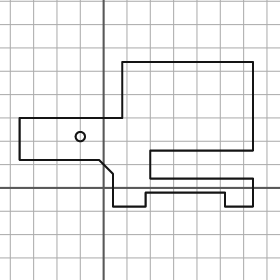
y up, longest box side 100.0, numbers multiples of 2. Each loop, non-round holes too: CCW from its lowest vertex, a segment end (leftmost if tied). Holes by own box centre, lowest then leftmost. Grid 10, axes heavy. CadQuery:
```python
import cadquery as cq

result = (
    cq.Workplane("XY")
    .moveTo(4.0, -8.0)
    .lineTo(18.0, -8.0)
    .lineTo(18.0, -2.0)
    .lineTo(52.0, -2.0)
    .lineTo(52.0, -8.0)
    .lineTo(64.0, -8.0)
    .lineTo(64.0, 4.0)
    .lineTo(20.0, 4.0)
    .lineTo(20.0, 16.0)
    .lineTo(64.0, 16.0)
    .lineTo(64.0, 54.0)
    .lineTo(8.0, 54.0)
    .lineTo(8.0, 30.0)
    .lineTo(-36.0, 30.0)
    .lineTo(-36.0, 12.0)
    .lineTo(-2.0, 12.0)
    .lineTo(4.0, 6.0)
    .close()
    .moveTo(-10.0, 22.0)
    .circle(2.0)
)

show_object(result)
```